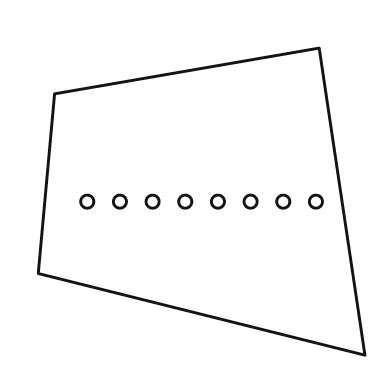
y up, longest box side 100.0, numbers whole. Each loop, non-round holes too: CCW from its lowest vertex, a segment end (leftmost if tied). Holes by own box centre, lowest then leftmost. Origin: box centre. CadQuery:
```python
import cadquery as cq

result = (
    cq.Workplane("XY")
    .moveTo(50.0, -47.0)
    .lineTo(36.0, 47.0)
    .lineTo(-45.0, 33.0)
    .lineTo(-50.0, -22.0)
    .close()
    .moveTo(-35.0, 0.0)
    .circle(2.0)
    .moveTo(-25.0, 0.0)
    .circle(2.0)
    .moveTo(-15.0, 0.0)
    .circle(2.0)
    .moveTo(-5.0, 0.0)
    .circle(2.0)
    .moveTo(5.0, 0.0)
    .circle(2.0)
    .moveTo(15.0, 0.0)
    .circle(2.0)
    .moveTo(25.0, 0.0)
    .circle(2.0)
    .moveTo(35.0, 0.0)
    .circle(2.0)
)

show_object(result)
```